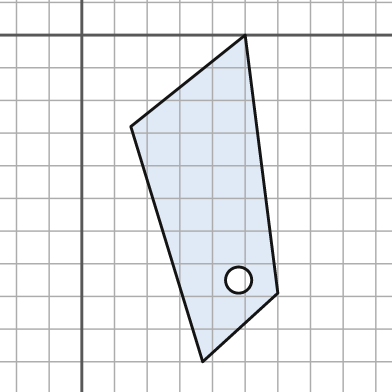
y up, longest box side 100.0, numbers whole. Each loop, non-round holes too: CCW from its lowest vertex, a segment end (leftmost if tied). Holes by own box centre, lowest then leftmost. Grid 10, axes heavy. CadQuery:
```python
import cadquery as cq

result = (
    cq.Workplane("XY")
    .moveTo(37.0, -100.0)
    .lineTo(60.0, -79.0)
    .lineTo(50.0, 0.0)
    .lineTo(15.0, -28.0)
    .close()
    .moveTo(48.0, -75.0)
    .circle(4.0)
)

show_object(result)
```